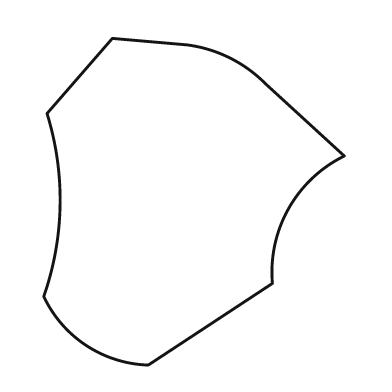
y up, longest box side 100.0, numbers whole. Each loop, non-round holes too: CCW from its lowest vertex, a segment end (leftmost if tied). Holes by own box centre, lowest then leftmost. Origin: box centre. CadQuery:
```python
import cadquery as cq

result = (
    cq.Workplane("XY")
    .moveTo(-14.0, -50.0)
    .lineTo(24.0, -25.0)
    .threePointArc((29.0, -2.0), (46.0, 14.0))
    .lineTo(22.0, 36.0)
    .threePointArc((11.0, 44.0), (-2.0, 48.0))
    .lineTo(-25.0, 50.0)
    .lineTo(-45.0, 27.0)
    .threePointArc((-41.0, -1.0), (-46.0, -29.0))
    .threePointArc((-33.0, -44.0), (-14.0, -50.0))
    .close()
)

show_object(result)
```